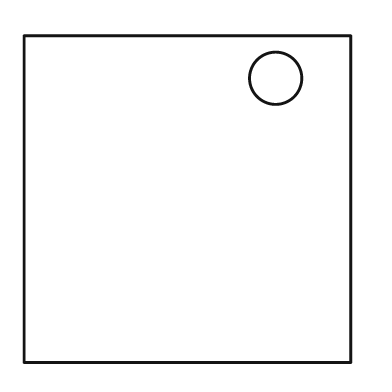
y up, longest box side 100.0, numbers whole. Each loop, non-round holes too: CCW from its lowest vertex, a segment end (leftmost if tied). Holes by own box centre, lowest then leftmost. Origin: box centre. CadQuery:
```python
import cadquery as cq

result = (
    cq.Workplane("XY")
    .moveTo(-50.0, -50.0)
    .lineTo(50.0, -50.0)
    .lineTo(50.0, 50.0)
    .lineTo(-50.0, 50.0)
    .close()
    .moveTo(27.0, 37.0)
    .circle(8.0)
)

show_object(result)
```